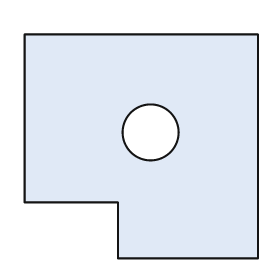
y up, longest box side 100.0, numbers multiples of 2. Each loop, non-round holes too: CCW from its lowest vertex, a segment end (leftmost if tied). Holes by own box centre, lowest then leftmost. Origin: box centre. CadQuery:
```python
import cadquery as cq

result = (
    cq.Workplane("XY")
    .moveTo(-10.0, -48.0)
    .lineTo(50.0, -48.0)
    .lineTo(50.0, 48.0)
    .lineTo(-50.0, 48.0)
    .lineTo(-50.0, -24.0)
    .lineTo(-10.0, -24.0)
    .close()
    .moveTo(4.0, 6.0)
    .circle(12.0)
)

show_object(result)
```